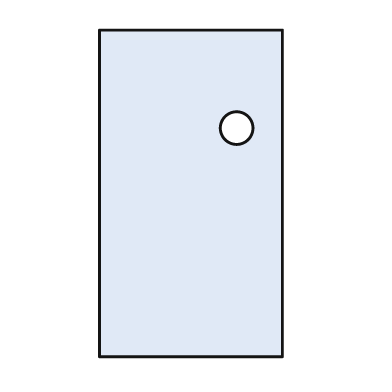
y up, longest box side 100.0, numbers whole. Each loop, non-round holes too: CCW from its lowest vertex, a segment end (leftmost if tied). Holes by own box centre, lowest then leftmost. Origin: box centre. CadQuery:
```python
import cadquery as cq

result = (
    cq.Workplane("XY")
    .moveTo(-28.0, -50.0)
    .lineTo(28.0, -50.0)
    .lineTo(28.0, 50.0)
    .lineTo(-28.0, 50.0)
    .close()
    .moveTo(14.0, 20.0)
    .circle(5.0)
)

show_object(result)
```